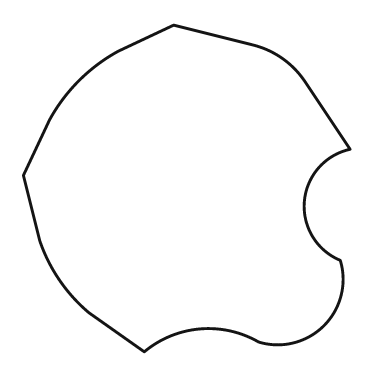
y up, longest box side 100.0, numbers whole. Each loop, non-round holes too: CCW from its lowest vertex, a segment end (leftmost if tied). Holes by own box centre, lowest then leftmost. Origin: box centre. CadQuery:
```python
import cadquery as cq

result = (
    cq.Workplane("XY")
    .moveTo(-13.0, -50.0)
    .threePointArc((4.0, -43.0), (22.0, -47.0))
    .threePointArc((42.0, -42.0), (47.0, -22.0))
    .threePointArc((36.0, -4.0), (50.0, 12.0))
    .lineTo(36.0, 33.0)
    .threePointArc((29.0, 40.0), (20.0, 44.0))
    .lineTo(-4.0, 50.0)
    .lineTo(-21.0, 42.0)
    .threePointArc((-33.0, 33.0), (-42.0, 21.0))
    .lineTo(-50.0, 4.0)
    .lineTo(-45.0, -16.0)
    .threePointArc((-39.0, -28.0), (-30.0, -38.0))
    .close()
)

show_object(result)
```